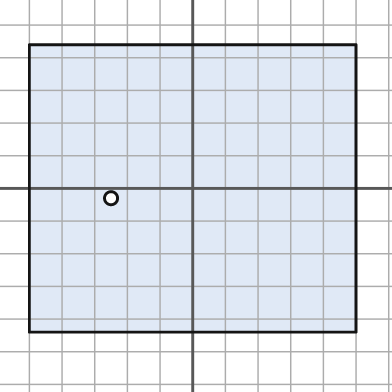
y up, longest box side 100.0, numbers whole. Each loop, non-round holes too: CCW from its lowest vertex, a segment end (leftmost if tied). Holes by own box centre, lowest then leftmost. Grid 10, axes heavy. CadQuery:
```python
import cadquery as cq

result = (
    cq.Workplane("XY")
    .moveTo(-50.0, -44.0)
    .lineTo(50.0, -44.0)
    .lineTo(50.0, 44.0)
    .lineTo(-50.0, 44.0)
    .close()
    .moveTo(-25.0, -3.0)
    .circle(2.0)
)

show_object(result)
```